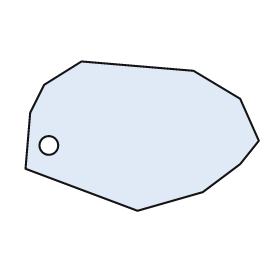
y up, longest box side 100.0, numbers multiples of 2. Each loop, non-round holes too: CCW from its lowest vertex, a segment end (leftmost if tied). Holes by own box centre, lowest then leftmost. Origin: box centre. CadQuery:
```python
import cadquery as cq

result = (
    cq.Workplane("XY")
    .moveTo(-2.0, -32.0)
    .lineTo(26.0, -24.0)
    .lineTo(42.0, -12.0)
    .lineTo(50.0, -2.0)
    .lineTo(42.0, 16.0)
    .lineTo(22.0, 28.0)
    .lineTo(-26.0, 32.0)
    .lineTo(-42.0, 22.0)
    .lineTo(-48.0, 10.0)
    .lineTo(-50.0, -14.0)
    .close()
    .moveTo(-40.0, -4.0)
    .circle(4.0)
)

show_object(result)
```